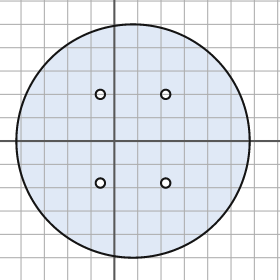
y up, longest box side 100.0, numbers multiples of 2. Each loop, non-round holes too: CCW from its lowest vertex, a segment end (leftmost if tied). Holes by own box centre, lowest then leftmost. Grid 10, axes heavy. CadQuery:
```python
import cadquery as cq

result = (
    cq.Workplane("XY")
    .moveTo(8.0, 0.0)
    .circle(50.0)
    .moveTo(-6.0, -18.0)
    .circle(2.0)
    .moveTo(22.0, -18.0)
    .circle(2.0)
    .moveTo(-6.0, 20.0)
    .circle(2.0)
    .moveTo(22.0, 20.0)
    .circle(2.0)
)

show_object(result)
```